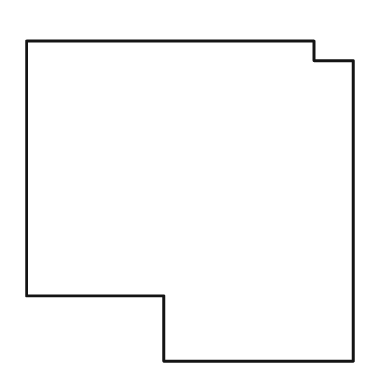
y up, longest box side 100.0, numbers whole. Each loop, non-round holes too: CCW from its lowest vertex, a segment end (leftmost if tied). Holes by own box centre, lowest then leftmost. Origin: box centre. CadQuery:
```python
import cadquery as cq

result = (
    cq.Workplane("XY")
    .moveTo(-8.0, -49.0)
    .lineTo(50.0, -49.0)
    .lineTo(50.0, 43.0)
    .lineTo(38.0, 43.0)
    .lineTo(38.0, 49.0)
    .lineTo(-50.0, 49.0)
    .lineTo(-50.0, -29.0)
    .lineTo(-8.0, -29.0)
    .close()
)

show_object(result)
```